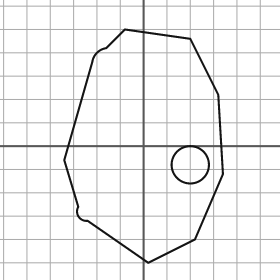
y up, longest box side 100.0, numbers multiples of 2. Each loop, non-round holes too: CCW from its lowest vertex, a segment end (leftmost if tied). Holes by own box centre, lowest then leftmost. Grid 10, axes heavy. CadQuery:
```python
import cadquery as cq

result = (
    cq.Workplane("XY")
    .moveTo(2.0, -50.0)
    .lineTo(22.0, -40.0)
    .lineTo(34.0, -12.0)
    .lineTo(32.0, 22.0)
    .lineTo(20.0, 46.0)
    .lineTo(-8.0, 50.0)
    .lineTo(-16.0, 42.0)
    .threePointArc((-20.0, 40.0), (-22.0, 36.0))
    .lineTo(-34.0, -6.0)
    .lineTo(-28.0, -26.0)
    .threePointArc((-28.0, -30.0), (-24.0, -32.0))
    .close()
    .moveTo(20.0, -8.0)
    .circle(8.0)
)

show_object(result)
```